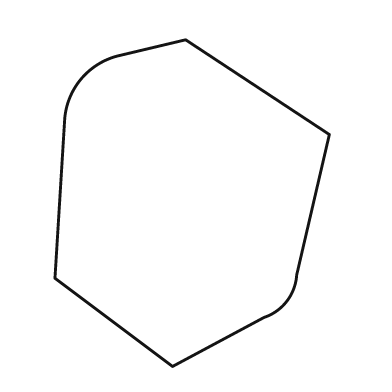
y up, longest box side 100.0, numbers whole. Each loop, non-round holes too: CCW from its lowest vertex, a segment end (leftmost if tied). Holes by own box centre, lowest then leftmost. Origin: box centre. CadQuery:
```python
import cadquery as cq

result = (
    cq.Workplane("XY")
    .moveTo(-6.0, -50.0)
    .lineTo(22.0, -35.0)
    .threePointArc((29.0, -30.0), (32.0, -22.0))
    .lineTo(42.0, 21.0)
    .lineTo(-2.0, 50.0)
    .lineTo(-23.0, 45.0)
    .threePointArc((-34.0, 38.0), (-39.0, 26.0))
    .lineTo(-42.0, -23.0)
    .close()
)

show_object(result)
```